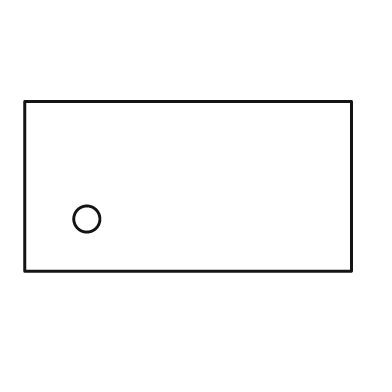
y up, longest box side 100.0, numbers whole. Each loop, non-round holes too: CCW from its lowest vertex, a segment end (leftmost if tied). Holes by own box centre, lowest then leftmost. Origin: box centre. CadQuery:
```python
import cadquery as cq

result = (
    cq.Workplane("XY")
    .moveTo(-50.0, -26.0)
    .lineTo(50.0, -26.0)
    .lineTo(50.0, 26.0)
    .lineTo(-50.0, 26.0)
    .close()
    .moveTo(-31.0, -10.0)
    .circle(4.0)
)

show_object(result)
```